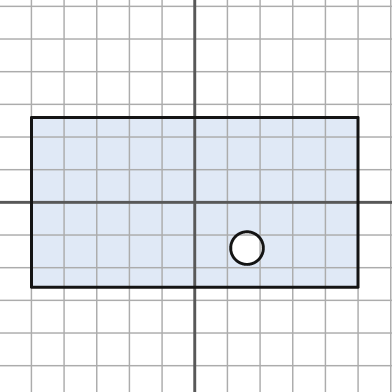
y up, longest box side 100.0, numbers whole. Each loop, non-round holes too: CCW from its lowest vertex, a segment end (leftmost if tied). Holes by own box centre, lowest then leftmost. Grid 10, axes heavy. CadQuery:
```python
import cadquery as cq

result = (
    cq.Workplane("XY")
    .moveTo(-50.0, -26.0)
    .lineTo(50.0, -26.0)
    .lineTo(50.0, 26.0)
    .lineTo(-50.0, 26.0)
    .close()
    .moveTo(16.0, -14.0)
    .circle(5.0)
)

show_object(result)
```